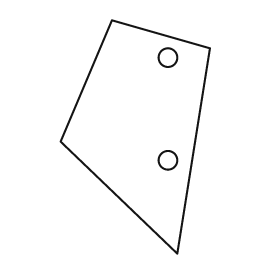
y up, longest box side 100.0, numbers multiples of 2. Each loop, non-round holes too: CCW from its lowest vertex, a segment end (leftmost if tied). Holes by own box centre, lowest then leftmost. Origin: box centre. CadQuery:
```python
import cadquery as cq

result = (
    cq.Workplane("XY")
    .moveTo(18.0, -50.0)
    .lineTo(32.0, 38.0)
    .lineTo(-10.0, 50.0)
    .lineTo(-32.0, -2.0)
    .close()
    .moveTo(14.0, -10.0)
    .circle(4.0)
    .moveTo(14.0, 34.0)
    .circle(4.0)
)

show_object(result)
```